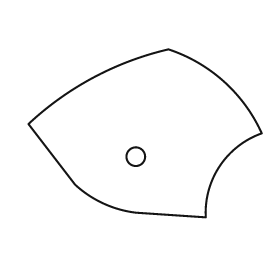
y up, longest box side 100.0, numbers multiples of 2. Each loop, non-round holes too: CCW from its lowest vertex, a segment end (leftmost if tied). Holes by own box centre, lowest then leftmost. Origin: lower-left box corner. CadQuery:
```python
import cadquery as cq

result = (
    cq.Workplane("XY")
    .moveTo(76.0, 0.0)
    .threePointArc((82.0, 22.0), (100.0, 36.0))
    .threePointArc((84.0, 58.0), (60.0, 72.0))
    .threePointArc((28.0, 60.0), (0.0, 40.0))
    .lineTo(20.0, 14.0)
    .threePointArc((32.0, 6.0), (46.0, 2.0))
    .close()
    .moveTo(46.0, 26.0)
    .circle(4.0)
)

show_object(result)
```